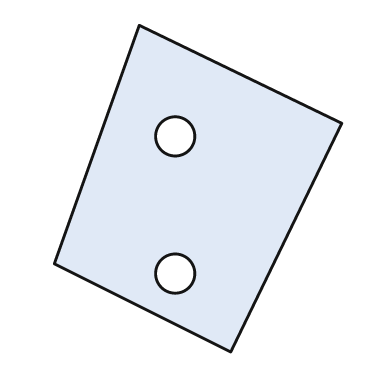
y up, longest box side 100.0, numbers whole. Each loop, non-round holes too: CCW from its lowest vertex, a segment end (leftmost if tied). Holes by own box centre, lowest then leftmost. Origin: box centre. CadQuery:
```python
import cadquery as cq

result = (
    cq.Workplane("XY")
    .moveTo(10.0, -50.0)
    .lineTo(44.0, 20.0)
    .lineTo(-18.0, 50.0)
    .lineTo(-44.0, -23.0)
    .close()
    .moveTo(-7.0, -26.0)
    .circle(6.0)
    .moveTo(-7.0, 16.0)
    .circle(6.0)
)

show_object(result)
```